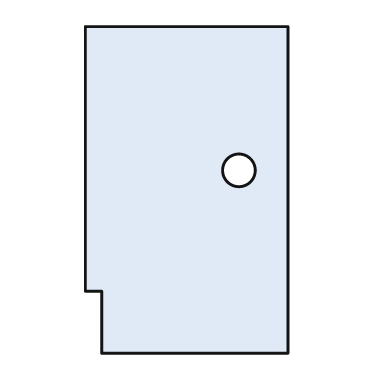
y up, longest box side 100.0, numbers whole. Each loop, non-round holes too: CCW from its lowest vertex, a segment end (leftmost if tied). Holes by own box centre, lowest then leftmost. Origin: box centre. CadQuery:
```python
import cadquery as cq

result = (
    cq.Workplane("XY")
    .moveTo(-26.0, -50.0)
    .lineTo(31.0, -50.0)
    .lineTo(31.0, 50.0)
    .lineTo(-31.0, 50.0)
    .lineTo(-31.0, -31.0)
    .lineTo(-26.0, -31.0)
    .close()
    .moveTo(16.0, 6.0)
    .circle(5.0)
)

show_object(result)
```